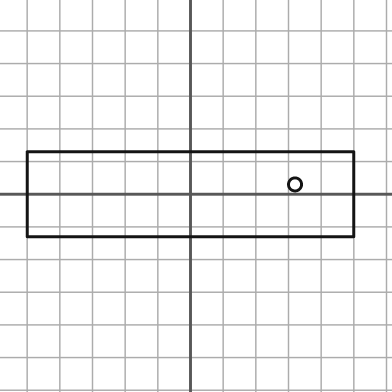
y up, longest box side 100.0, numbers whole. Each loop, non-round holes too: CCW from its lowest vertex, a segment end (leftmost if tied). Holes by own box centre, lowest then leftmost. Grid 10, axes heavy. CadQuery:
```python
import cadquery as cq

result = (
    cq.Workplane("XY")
    .moveTo(-50.0, -13.0)
    .lineTo(50.0, -13.0)
    .lineTo(50.0, 13.0)
    .lineTo(-50.0, 13.0)
    .close()
    .moveTo(32.0, 3.0)
    .circle(2.0)
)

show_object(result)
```